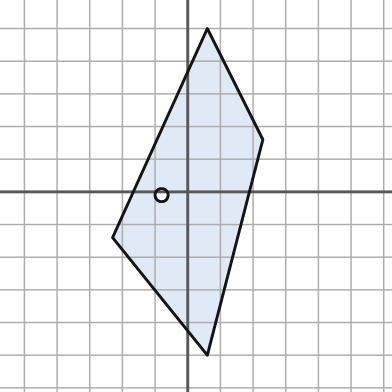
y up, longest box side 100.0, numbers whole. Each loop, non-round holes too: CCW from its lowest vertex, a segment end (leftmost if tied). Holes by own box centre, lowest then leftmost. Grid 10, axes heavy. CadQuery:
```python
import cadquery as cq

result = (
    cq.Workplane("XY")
    .moveTo(6.0, -50.0)
    .lineTo(23.0, 16.0)
    .lineTo(6.0, 50.0)
    .lineTo(-23.0, -14.0)
    .close()
    .moveTo(-8.0, -1.0)
    .circle(2.0)
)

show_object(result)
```